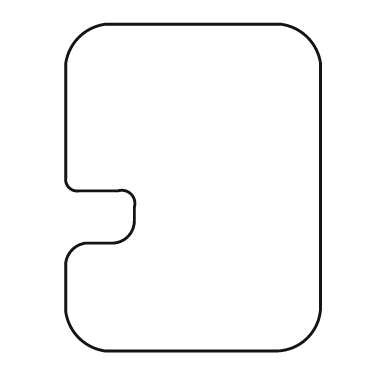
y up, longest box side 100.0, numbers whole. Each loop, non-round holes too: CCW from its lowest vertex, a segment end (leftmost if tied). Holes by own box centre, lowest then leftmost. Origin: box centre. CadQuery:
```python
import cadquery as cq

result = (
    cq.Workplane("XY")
    .moveTo(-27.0, -50.0)
    .lineTo(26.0, -50.0)
    .threePointArc((35.0, -46.0), (39.0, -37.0))
    .lineTo(39.0, 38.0)
    .threePointArc((35.0, 46.0), (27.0, 50.0))
    .lineTo(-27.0, 50.0)
    .threePointArc((-35.0, 46.0), (-39.0, 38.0))
    .lineTo(-39.0, 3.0)
    .threePointArc((-38.0, 0.0), (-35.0, -1.0))
    .lineTo(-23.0, -1.0)
    .threePointArc((-19.0, -2.0), (-18.0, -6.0))
    .lineTo(-18.0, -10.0)
    .threePointArc((-20.0, -15.0), (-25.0, -17.0))
    .lineTo(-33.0, -17.0)
    .threePointArc((-37.0, -19.0), (-39.0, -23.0))
    .lineTo(-39.0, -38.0)
    .threePointArc((-35.0, -46.0), (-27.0, -50.0))
    .close()
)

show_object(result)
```